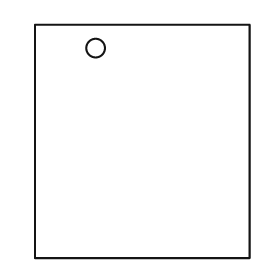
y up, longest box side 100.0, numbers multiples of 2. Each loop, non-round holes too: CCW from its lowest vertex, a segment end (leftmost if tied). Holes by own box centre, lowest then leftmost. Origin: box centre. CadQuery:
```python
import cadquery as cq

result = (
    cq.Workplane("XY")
    .moveTo(-46.0, -50.0)
    .lineTo(46.0, -50.0)
    .lineTo(46.0, 50.0)
    .lineTo(-46.0, 50.0)
    .close()
    .moveTo(-20.0, 40.0)
    .circle(4.0)
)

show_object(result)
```